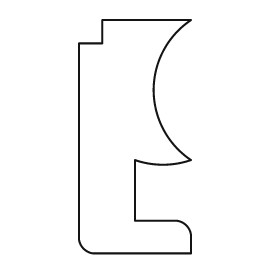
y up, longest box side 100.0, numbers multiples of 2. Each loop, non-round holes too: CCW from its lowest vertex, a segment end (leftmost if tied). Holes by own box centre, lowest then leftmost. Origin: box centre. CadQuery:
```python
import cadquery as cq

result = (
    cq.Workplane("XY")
    .moveTo(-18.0, -50.0)
    .lineTo(24.0, -50.0)
    .lineTo(24.0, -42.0)
    .threePointArc((22.0, -38.0), (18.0, -36.0))
    .lineTo(0.0, -36.0)
    .lineTo(0.0, -10.0)
    .threePointArc((12.0, -12.0), (24.0, -10.0))
    .threePointArc((8.0, 20.0), (24.0, 50.0))
    .lineTo(-14.0, 50.0)
    .lineTo(-14.0, 40.0)
    .lineTo(-24.0, 40.0)
    .lineTo(-24.0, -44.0)
    .threePointArc((-22.0, -48.0), (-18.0, -50.0))
    .close()
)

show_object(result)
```